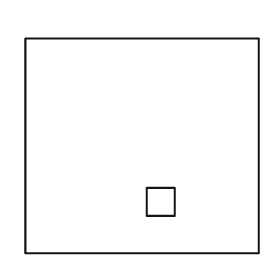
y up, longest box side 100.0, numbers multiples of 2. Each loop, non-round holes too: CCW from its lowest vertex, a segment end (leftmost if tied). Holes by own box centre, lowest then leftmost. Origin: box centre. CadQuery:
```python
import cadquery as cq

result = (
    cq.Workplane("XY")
    .moveTo(-50.0, -46.0)
    .lineTo(50.0, -46.0)
    .lineTo(50.0, 46.0)
    .lineTo(-50.0, 46.0)
    .close()
    .moveTo(2.0, -30.0)
    .lineTo(14.0, -30.0)
    .lineTo(14.0, -18.0)
    .lineTo(2.0, -18.0)
    .close()
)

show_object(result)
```